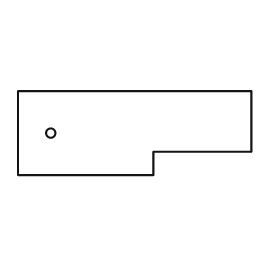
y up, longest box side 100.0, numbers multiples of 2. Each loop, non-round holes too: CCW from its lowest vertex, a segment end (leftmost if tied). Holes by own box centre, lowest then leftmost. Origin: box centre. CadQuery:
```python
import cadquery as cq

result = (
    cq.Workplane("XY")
    .moveTo(-50.0, -18.0)
    .lineTo(8.0, -18.0)
    .lineTo(8.0, -8.0)
    .lineTo(50.0, -8.0)
    .lineTo(50.0, 18.0)
    .lineTo(-50.0, 18.0)
    .close()
    .moveTo(-36.0, 0.0)
    .circle(2.0)
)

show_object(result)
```